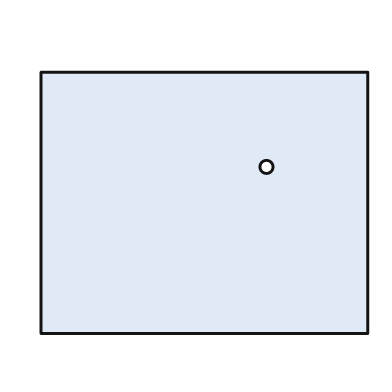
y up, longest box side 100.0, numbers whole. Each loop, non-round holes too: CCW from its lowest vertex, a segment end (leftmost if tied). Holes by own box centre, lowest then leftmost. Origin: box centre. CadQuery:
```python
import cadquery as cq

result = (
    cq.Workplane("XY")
    .moveTo(-50.0, -40.0)
    .lineTo(50.0, -40.0)
    .lineTo(50.0, 40.0)
    .lineTo(-50.0, 40.0)
    .close()
    .moveTo(19.0, 11.0)
    .circle(2.0)
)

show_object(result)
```